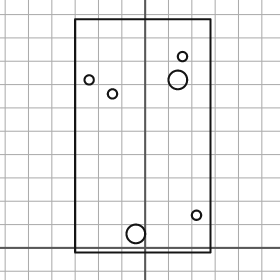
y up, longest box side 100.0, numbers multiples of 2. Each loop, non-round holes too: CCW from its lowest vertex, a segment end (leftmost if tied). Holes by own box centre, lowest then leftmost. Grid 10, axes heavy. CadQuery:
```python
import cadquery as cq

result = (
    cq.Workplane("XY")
    .moveTo(-30.0, -2.0)
    .lineTo(28.0, -2.0)
    .lineTo(28.0, 98.0)
    .lineTo(-30.0, 98.0)
    .close()
    .moveTo(-4.0, 6.0)
    .circle(4.0)
    .moveTo(22.0, 14.0)
    .circle(2.0)
    .moveTo(-14.0, 66.0)
    .circle(2.0)
    .moveTo(-24.0, 72.0)
    .circle(2.0)
    .moveTo(14.0, 72.0)
    .circle(4.0)
    .moveTo(16.0, 82.0)
    .circle(2.0)
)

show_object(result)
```